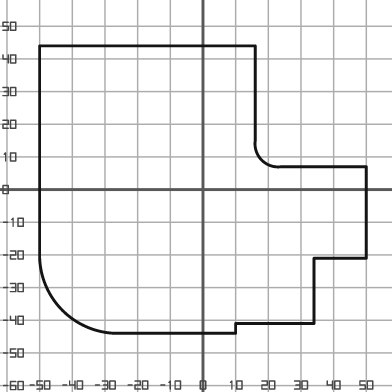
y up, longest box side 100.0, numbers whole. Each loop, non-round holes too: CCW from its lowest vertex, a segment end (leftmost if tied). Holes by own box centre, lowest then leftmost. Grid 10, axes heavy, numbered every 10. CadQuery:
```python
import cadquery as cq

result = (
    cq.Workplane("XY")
    .moveTo(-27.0, -44.0)
    .lineTo(10.0, -44.0)
    .lineTo(10.0, -41.0)
    .lineTo(34.0, -41.0)
    .lineTo(34.0, -21.0)
    .lineTo(50.0, -21.0)
    .lineTo(50.0, 7.0)
    .lineTo(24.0, 7.0)
    .threePointArc((18.0, 9.0), (16.0, 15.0))
    .lineTo(16.0, 44.0)
    .lineTo(-50.0, 44.0)
    .lineTo(-50.0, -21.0)
    .threePointArc((-43.0, -37.0), (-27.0, -44.0))
    .close()
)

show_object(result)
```